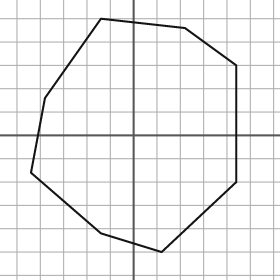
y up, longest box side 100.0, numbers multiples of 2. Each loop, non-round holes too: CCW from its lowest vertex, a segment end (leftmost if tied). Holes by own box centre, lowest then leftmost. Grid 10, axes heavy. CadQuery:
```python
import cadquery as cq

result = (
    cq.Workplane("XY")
    .moveTo(12.0, -50.0)
    .lineTo(44.0, -20.0)
    .lineTo(44.0, 30.0)
    .lineTo(22.0, 46.0)
    .lineTo(-14.0, 50.0)
    .lineTo(-38.0, 16.0)
    .lineTo(-44.0, -16.0)
    .lineTo(-14.0, -42.0)
    .close()
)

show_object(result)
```